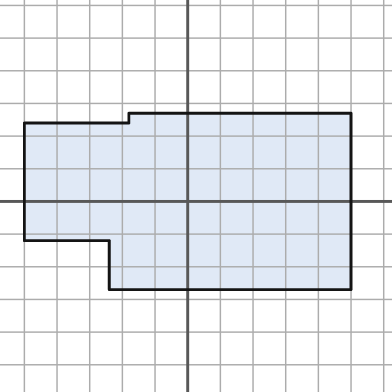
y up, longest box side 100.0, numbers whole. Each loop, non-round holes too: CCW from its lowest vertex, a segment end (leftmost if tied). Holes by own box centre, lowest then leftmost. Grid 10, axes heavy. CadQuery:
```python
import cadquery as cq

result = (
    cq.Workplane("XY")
    .moveTo(-24.0, -27.0)
    .lineTo(50.0, -27.0)
    .lineTo(50.0, 27.0)
    .lineTo(-18.0, 27.0)
    .lineTo(-18.0, 24.0)
    .lineTo(-50.0, 24.0)
    .lineTo(-50.0, -12.0)
    .lineTo(-24.0, -12.0)
    .close()
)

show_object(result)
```